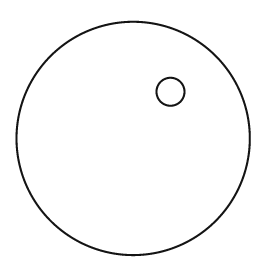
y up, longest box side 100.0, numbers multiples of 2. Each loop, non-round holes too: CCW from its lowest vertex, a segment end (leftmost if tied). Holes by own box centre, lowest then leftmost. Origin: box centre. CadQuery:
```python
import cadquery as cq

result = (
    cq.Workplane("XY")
    .moveTo(0.0, 0.0)
    .circle(50.0)
    .moveTo(16.0, 20.0)
    .circle(6.0)
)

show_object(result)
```